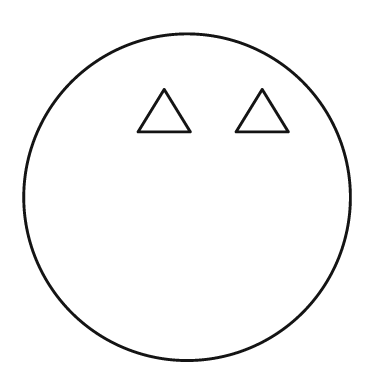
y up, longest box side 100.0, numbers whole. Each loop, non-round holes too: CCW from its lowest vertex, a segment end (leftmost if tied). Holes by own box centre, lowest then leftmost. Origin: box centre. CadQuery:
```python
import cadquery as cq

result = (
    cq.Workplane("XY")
    .moveTo(0.0, 0.0)
    .circle(50.0)
    .moveTo(-15.0, 20.0)
    .lineTo(1.0, 20.0)
    .lineTo(-7.0, 33.0)
    .close()
    .moveTo(15.0, 20.0)
    .lineTo(31.0, 20.0)
    .lineTo(23.0, 33.0)
    .close()
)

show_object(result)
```